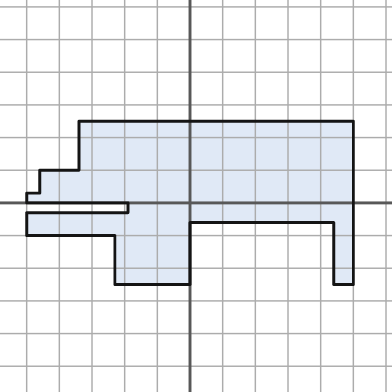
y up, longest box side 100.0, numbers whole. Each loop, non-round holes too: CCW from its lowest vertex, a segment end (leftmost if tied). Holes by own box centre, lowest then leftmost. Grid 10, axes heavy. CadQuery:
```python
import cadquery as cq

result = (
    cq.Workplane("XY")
    .moveTo(-23.0, -25.0)
    .lineTo(0.0, -25.0)
    .lineTo(0.0, -6.0)
    .lineTo(44.0, -6.0)
    .lineTo(44.0, -25.0)
    .lineTo(50.0, -25.0)
    .lineTo(50.0, 25.0)
    .lineTo(-34.0, 25.0)
    .lineTo(-34.0, 10.0)
    .lineTo(-46.0, 10.0)
    .lineTo(-46.0, 3.0)
    .lineTo(-50.0, 3.0)
    .lineTo(-50.0, 0.0)
    .lineTo(-19.0, 0.0)
    .lineTo(-19.0, -3.0)
    .lineTo(-50.0, -3.0)
    .lineTo(-50.0, -10.0)
    .lineTo(-23.0, -10.0)
    .close()
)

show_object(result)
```